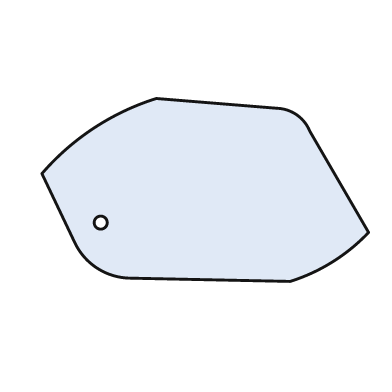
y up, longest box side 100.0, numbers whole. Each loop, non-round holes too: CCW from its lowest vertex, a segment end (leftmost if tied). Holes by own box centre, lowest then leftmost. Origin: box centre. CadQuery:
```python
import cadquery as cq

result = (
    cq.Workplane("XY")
    .moveTo(26.0, -28.0)
    .threePointArc((39.0, -22.0), (50.0, -13.0))
    .lineTo(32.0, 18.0)
    .threePointArc((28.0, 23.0), (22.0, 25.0))
    .lineTo(-15.0, 28.0)
    .threePointArc((-34.0, 19.0), (-50.0, 5.0))
    .lineTo(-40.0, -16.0)
    .threePointArc((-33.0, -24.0), (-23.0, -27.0))
    .close()
    .moveTo(-32.0, -10.0)
    .circle(2.0)
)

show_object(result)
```